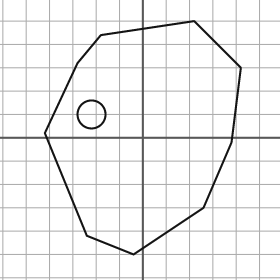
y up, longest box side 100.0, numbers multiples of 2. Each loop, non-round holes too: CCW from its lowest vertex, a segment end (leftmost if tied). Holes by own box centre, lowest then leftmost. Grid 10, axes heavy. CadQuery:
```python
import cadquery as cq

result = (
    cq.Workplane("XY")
    .moveTo(-4.0, -50.0)
    .lineTo(26.0, -30.0)
    .lineTo(38.0, -2.0)
    .lineTo(42.0, 30.0)
    .lineTo(22.0, 50.0)
    .lineTo(-18.0, 44.0)
    .lineTo(-28.0, 32.0)
    .lineTo(-42.0, 2.0)
    .lineTo(-24.0, -42.0)
    .close()
    .moveTo(-22.0, 10.0)
    .circle(6.0)
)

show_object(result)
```